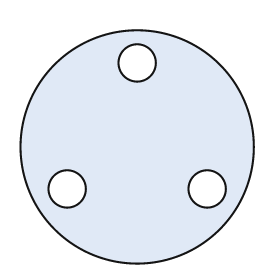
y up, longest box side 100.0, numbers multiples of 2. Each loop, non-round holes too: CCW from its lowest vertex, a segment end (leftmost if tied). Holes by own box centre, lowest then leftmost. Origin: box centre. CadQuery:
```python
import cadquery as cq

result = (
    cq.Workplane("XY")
    .moveTo(0.0, 0.0)
    .circle(50.0)
    .moveTo(-30.0, -18.0)
    .circle(8.0)
    .moveTo(30.0, -18.0)
    .circle(8.0)
    .moveTo(0.0, 36.0)
    .circle(8.0)
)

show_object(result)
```